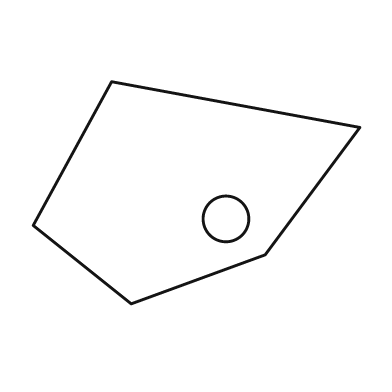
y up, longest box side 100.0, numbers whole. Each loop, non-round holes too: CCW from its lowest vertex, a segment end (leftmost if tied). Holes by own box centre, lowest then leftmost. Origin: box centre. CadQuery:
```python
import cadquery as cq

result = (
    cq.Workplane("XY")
    .moveTo(-20.0, -34.0)
    .lineTo(21.0, -19.0)
    .lineTo(50.0, 20.0)
    .lineTo(-26.0, 34.0)
    .lineTo(-50.0, -10.0)
    .close()
    .moveTo(9.0, -8.0)
    .circle(7.0)
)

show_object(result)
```